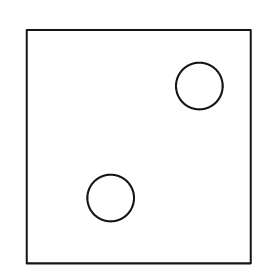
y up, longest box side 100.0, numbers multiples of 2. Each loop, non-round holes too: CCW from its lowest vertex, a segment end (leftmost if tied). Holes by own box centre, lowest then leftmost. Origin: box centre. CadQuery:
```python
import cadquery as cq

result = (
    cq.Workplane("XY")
    .moveTo(-48.0, -50.0)
    .lineTo(48.0, -50.0)
    .lineTo(48.0, 50.0)
    .lineTo(-48.0, 50.0)
    .close()
    .moveTo(-12.0, -22.0)
    .circle(10.0)
    .moveTo(26.0, 26.0)
    .circle(10.0)
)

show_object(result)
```